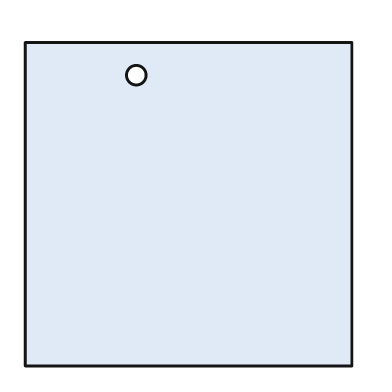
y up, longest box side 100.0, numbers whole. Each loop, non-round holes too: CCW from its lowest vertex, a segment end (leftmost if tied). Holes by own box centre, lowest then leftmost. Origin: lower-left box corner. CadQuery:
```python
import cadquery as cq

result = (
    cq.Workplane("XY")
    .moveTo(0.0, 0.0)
    .lineTo(100.0, 0.0)
    .lineTo(100.0, 99.0)
    .lineTo(0.0, 99.0)
    .close()
    .moveTo(34.0, 89.0)
    .circle(3.0)
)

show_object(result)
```